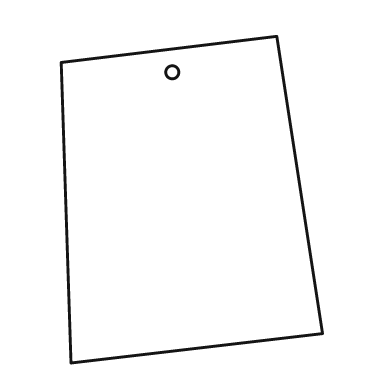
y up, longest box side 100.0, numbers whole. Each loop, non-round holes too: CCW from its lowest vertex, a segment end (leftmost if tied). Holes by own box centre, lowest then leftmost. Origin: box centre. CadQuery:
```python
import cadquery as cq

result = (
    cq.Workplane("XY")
    .moveTo(-37.0, -50.0)
    .lineTo(40.0, -41.0)
    .lineTo(26.0, 50.0)
    .lineTo(-40.0, 42.0)
    .close()
    .moveTo(-6.0, 39.0)
    .circle(2.0)
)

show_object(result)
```